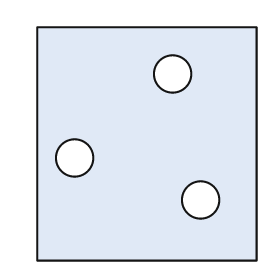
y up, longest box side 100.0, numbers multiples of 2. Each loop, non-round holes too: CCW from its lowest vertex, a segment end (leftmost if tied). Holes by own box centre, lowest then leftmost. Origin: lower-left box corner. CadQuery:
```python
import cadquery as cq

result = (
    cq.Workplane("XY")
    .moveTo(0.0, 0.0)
    .lineTo(94.0, 0.0)
    .lineTo(94.0, 100.0)
    .lineTo(0.0, 100.0)
    .close()
    .moveTo(70.0, 26.0)
    .circle(8.0)
    .moveTo(16.0, 44.0)
    .circle(8.0)
    .moveTo(58.0, 80.0)
    .circle(8.0)
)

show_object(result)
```